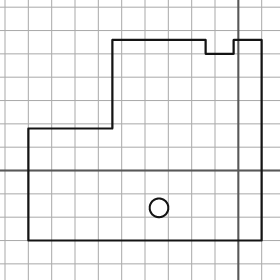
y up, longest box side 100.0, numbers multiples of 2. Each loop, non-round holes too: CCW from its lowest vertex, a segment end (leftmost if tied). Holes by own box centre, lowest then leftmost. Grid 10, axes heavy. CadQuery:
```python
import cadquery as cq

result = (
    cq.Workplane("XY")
    .moveTo(-90.0, -30.0)
    .lineTo(10.0, -30.0)
    .lineTo(10.0, 56.0)
    .lineTo(-2.0, 56.0)
    .lineTo(-2.0, 50.0)
    .lineTo(-14.0, 50.0)
    .lineTo(-14.0, 56.0)
    .lineTo(-54.0, 56.0)
    .lineTo(-54.0, 18.0)
    .lineTo(-90.0, 18.0)
    .close()
    .moveTo(-34.0, -16.0)
    .circle(4.0)
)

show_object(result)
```